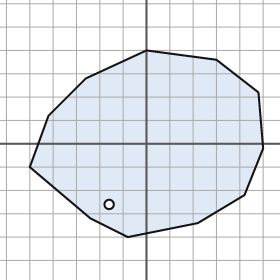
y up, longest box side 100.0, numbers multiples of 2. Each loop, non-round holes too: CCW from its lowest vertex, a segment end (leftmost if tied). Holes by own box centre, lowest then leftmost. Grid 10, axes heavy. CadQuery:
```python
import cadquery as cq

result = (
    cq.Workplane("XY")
    .moveTo(-8.0, -40.0)
    .lineTo(22.0, -34.0)
    .lineTo(42.0, -22.0)
    .lineTo(50.0, -2.0)
    .lineTo(48.0, 22.0)
    .lineTo(30.0, 36.0)
    .lineTo(0.0, 40.0)
    .lineTo(-26.0, 28.0)
    .lineTo(-42.0, 12.0)
    .lineTo(-50.0, -10.0)
    .lineTo(-24.0, -32.0)
    .close()
    .moveTo(-16.0, -26.0)
    .circle(2.0)
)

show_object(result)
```